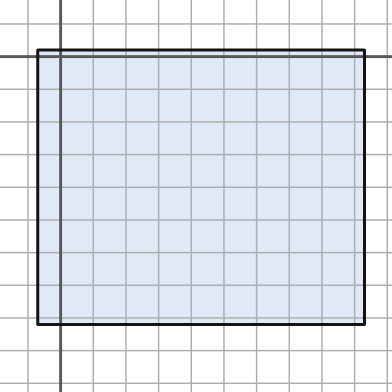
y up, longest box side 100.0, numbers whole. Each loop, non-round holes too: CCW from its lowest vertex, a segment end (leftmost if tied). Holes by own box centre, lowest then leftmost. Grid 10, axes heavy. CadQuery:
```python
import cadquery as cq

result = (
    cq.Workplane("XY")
    .moveTo(-7.0, -82.0)
    .lineTo(93.0, -82.0)
    .lineTo(93.0, 2.0)
    .lineTo(-7.0, 2.0)
    .close()
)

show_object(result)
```